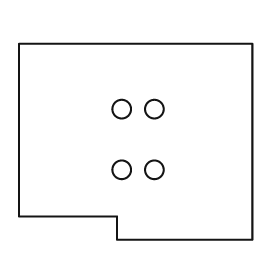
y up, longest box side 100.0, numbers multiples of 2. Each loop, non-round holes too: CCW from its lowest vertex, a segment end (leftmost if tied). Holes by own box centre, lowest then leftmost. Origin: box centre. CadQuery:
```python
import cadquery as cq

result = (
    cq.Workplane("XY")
    .moveTo(-8.0, -42.0)
    .lineTo(50.0, -42.0)
    .lineTo(50.0, 42.0)
    .lineTo(-50.0, 42.0)
    .lineTo(-50.0, -32.0)
    .lineTo(-8.0, -32.0)
    .close()
    .moveTo(-6.0, -12.0)
    .circle(4.0)
    .moveTo(8.0, -12.0)
    .circle(4.0)
    .moveTo(-6.0, 14.0)
    .circle(4.0)
    .moveTo(8.0, 14.0)
    .circle(4.0)
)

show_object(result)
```